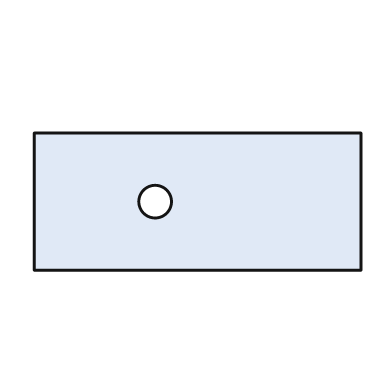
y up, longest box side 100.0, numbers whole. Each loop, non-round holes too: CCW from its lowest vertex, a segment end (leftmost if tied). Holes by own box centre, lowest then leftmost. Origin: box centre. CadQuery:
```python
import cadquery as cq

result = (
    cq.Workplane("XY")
    .moveTo(-50.0, -21.0)
    .lineTo(50.0, -21.0)
    .lineTo(50.0, 21.0)
    .lineTo(-50.0, 21.0)
    .close()
    .moveTo(-13.0, 0.0)
    .circle(5.0)
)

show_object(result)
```